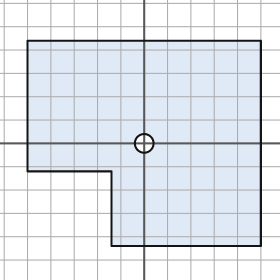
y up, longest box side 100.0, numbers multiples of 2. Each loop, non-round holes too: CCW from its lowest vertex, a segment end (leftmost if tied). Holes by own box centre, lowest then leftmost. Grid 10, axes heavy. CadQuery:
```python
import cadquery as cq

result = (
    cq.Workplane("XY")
    .moveTo(-14.0, -44.0)
    .lineTo(50.0, -44.0)
    .lineTo(50.0, 44.0)
    .lineTo(-50.0, 44.0)
    .lineTo(-50.0, -12.0)
    .lineTo(-14.0, -12.0)
    .close()
    .moveTo(0.0, 0.0)
    .circle(4.0)
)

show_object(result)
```